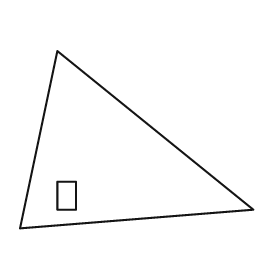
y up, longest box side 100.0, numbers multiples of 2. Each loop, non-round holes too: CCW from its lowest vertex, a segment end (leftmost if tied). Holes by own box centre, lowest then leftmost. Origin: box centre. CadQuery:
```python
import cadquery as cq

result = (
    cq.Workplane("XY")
    .moveTo(-50.0, -38.0)
    .lineTo(50.0, -30.0)
    .lineTo(-34.0, 38.0)
    .close()
    .moveTo(-34.0, -30.0)
    .lineTo(-26.0, -30.0)
    .lineTo(-26.0, -18.0)
    .lineTo(-34.0, -18.0)
    .close()
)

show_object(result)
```